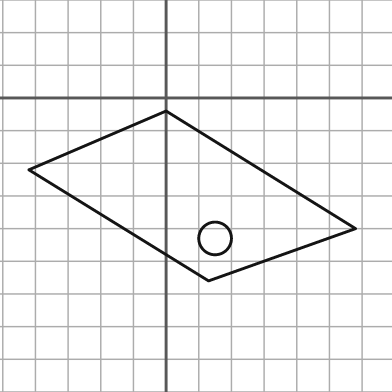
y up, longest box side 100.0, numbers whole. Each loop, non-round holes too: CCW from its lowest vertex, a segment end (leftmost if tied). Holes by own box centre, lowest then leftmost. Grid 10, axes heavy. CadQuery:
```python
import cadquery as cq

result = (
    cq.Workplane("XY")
    .moveTo(13.0, -56.0)
    .lineTo(58.0, -40.0)
    .lineTo(0.0, -4.0)
    .lineTo(-42.0, -22.0)
    .close()
    .moveTo(15.0, -43.0)
    .circle(5.0)
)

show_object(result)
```